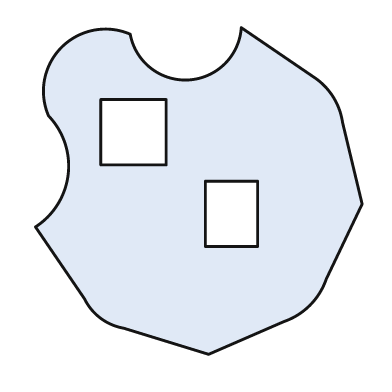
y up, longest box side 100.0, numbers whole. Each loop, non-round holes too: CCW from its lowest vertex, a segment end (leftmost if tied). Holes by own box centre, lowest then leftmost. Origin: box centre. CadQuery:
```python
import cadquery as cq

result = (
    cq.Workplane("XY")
    .moveTo(3.0, -50.0)
    .lineTo(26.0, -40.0)
    .threePointArc((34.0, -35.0), (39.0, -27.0))
    .lineTo(50.0, -4.0)
    .lineTo(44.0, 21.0)
    .threePointArc((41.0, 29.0), (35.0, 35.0))
    .lineTo(13.0, 50.0)
    .threePointArc((-3.0, 34.0), (-21.0, 48.0))
    .threePointArc((-42.0, 44.0), (-46.0, 23.0))
    .threePointArc((-40.0, 5.0), (-50.0, -11.0))
    .lineTo(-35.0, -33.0)
    .threePointArc((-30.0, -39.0), (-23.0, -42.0))
    .close()
    .moveTo(2.0, -17.0)
    .lineTo(18.0, -17.0)
    .lineTo(18.0, 3.0)
    .lineTo(2.0, 3.0)
    .close()
    .moveTo(-30.0, 8.0)
    .lineTo(-10.0, 8.0)
    .lineTo(-10.0, 28.0)
    .lineTo(-30.0, 28.0)
    .close()
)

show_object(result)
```